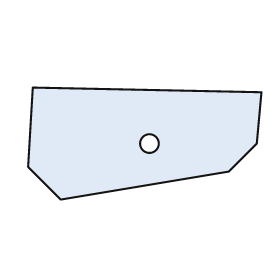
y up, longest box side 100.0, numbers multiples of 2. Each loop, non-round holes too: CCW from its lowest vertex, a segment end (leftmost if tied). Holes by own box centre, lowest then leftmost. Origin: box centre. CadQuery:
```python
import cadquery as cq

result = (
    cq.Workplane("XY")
    .moveTo(-36.0, -24.0)
    .lineTo(36.0, -12.0)
    .lineTo(48.0, 0.0)
    .lineTo(50.0, 22.0)
    .lineTo(-48.0, 24.0)
    .lineTo(-50.0, -10.0)
    .close()
    .moveTo(2.0, 0.0)
    .circle(4.0)
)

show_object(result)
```